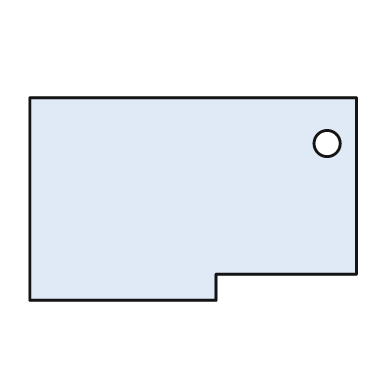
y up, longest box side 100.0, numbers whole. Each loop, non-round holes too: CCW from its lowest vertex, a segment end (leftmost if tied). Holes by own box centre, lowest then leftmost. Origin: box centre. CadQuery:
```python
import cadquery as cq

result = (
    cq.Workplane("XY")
    .moveTo(-50.0, -31.0)
    .lineTo(7.0, -31.0)
    .lineTo(7.0, -23.0)
    .lineTo(50.0, -23.0)
    .lineTo(50.0, 31.0)
    .lineTo(-50.0, 31.0)
    .close()
    .moveTo(41.0, 17.0)
    .circle(4.0)
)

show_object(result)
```